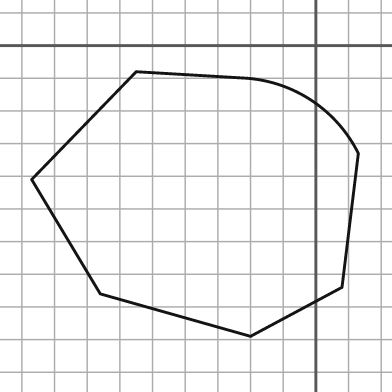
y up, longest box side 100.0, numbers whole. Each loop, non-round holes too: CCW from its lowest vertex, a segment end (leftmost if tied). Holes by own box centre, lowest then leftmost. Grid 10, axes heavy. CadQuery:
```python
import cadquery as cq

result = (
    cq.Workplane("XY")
    .moveTo(-20.0, -89.0)
    .lineTo(8.0, -74.0)
    .lineTo(13.0, -33.0)
    .threePointArc((-1.0, -17.0), (-21.0, -10.0))
    .lineTo(-55.0, -8.0)
    .lineTo(-87.0, -41.0)
    .lineTo(-66.0, -76.0)
    .close()
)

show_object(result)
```